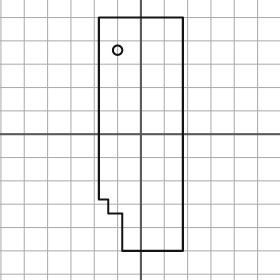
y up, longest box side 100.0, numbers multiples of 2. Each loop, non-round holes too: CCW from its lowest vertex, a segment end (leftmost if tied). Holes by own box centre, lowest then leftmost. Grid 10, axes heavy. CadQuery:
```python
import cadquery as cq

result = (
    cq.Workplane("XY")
    .moveTo(-8.0, -50.0)
    .lineTo(18.0, -50.0)
    .lineTo(18.0, 50.0)
    .lineTo(-18.0, 50.0)
    .lineTo(-18.0, -28.0)
    .lineTo(-14.0, -28.0)
    .lineTo(-14.0, -34.0)
    .lineTo(-8.0, -34.0)
    .close()
    .moveTo(-10.0, 36.0)
    .circle(2.0)
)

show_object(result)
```